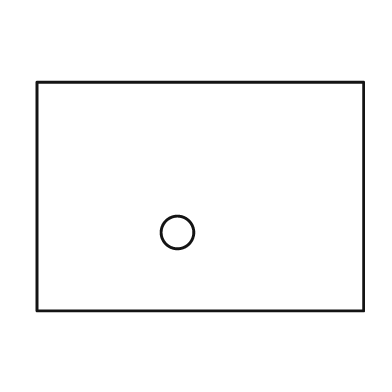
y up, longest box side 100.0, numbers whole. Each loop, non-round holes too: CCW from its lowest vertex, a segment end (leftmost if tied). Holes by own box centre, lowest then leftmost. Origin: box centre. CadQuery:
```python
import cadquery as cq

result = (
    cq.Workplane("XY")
    .moveTo(-50.0, -35.0)
    .lineTo(50.0, -35.0)
    .lineTo(50.0, 35.0)
    .lineTo(-50.0, 35.0)
    .close()
    .moveTo(-7.0, -11.0)
    .circle(5.0)
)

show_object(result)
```